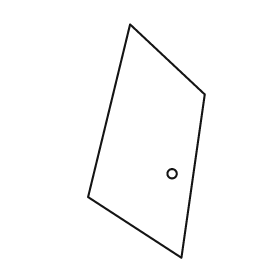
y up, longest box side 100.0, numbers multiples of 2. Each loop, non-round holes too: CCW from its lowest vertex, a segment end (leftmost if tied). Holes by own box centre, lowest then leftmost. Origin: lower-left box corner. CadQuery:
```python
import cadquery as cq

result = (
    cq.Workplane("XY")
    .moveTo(40.0, 0.0)
    .lineTo(50.0, 70.0)
    .lineTo(18.0, 100.0)
    .lineTo(0.0, 26.0)
    .close()
    .moveTo(36.0, 36.0)
    .circle(2.0)
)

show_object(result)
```